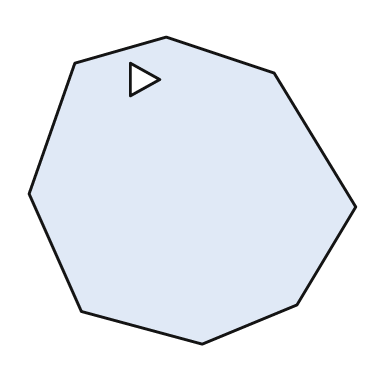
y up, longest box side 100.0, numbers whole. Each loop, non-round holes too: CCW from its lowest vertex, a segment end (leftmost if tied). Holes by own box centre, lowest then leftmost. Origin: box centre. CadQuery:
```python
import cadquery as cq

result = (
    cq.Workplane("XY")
    .moveTo(3.0, -47.0)
    .lineTo(32.0, -35.0)
    .lineTo(50.0, -5.0)
    .lineTo(25.0, 36.0)
    .lineTo(-8.0, 47.0)
    .lineTo(-36.0, 39.0)
    .lineTo(-50.0, -1.0)
    .lineTo(-34.0, -37.0)
    .close()
    .moveTo(-19.0, 29.0)
    .lineTo(-10.0, 34.0)
    .lineTo(-19.0, 39.0)
    .close()
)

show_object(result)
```